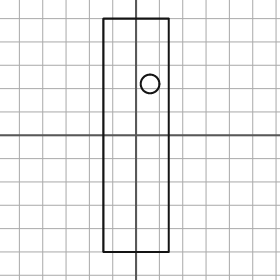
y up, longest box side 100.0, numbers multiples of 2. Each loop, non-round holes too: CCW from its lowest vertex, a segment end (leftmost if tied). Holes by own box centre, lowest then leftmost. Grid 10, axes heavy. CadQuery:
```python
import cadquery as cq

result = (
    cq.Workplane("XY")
    .moveTo(-14.0, -50.0)
    .lineTo(14.0, -50.0)
    .lineTo(14.0, 50.0)
    .lineTo(-14.0, 50.0)
    .close()
    .moveTo(6.0, 22.0)
    .circle(4.0)
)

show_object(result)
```